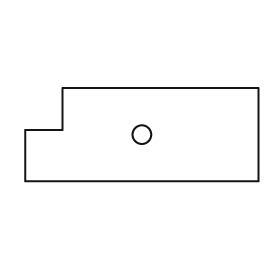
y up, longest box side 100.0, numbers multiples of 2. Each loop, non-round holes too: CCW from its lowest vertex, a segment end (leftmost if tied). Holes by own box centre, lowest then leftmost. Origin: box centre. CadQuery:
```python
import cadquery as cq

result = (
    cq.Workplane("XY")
    .moveTo(-50.0, -20.0)
    .lineTo(50.0, -20.0)
    .lineTo(50.0, 20.0)
    .lineTo(-34.0, 20.0)
    .lineTo(-34.0, 2.0)
    .lineTo(-50.0, 2.0)
    .close()
    .moveTo(0.0, 0.0)
    .circle(4.0)
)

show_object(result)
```